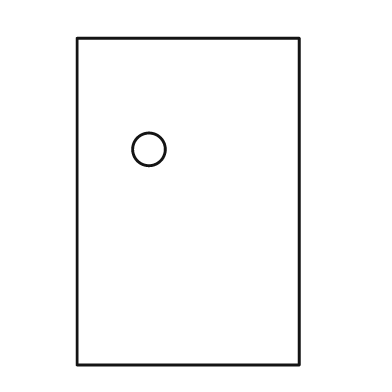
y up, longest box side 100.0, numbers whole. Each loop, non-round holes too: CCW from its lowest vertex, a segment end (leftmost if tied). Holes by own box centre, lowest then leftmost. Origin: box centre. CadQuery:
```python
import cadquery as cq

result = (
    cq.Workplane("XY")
    .moveTo(-34.0, -50.0)
    .lineTo(34.0, -50.0)
    .lineTo(34.0, 50.0)
    .lineTo(-34.0, 50.0)
    .close()
    .moveTo(-12.0, 16.0)
    .circle(5.0)
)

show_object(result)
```